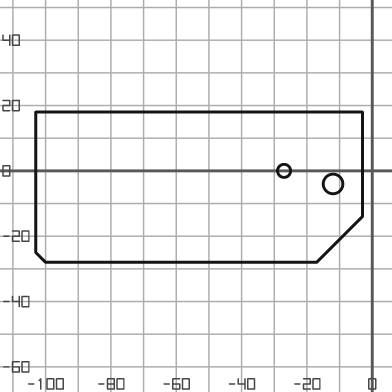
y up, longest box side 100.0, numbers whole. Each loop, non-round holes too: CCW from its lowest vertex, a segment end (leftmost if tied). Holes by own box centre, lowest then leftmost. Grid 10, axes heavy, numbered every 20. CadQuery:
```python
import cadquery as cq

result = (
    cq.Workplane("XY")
    .moveTo(-100.0, -28.0)
    .lineTo(-17.0, -28.0)
    .lineTo(-3.0, -14.0)
    .lineTo(-3.0, 18.0)
    .lineTo(-103.0, 18.0)
    .lineTo(-103.0, -25.0)
    .close()
    .moveTo(-12.0, -4.0)
    .circle(3.0)
    .moveTo(-27.0, 0.0)
    .circle(2.0)
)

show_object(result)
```